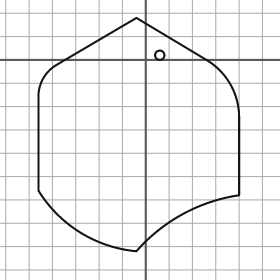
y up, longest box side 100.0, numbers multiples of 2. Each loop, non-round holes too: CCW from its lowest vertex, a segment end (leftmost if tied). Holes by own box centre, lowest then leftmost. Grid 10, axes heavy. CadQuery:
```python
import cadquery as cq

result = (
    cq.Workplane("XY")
    .moveTo(-4.0, -82.0)
    .threePointArc((16.0, -66.0), (40.0, -58.0))
    .lineTo(40.0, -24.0)
    .threePointArc((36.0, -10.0), (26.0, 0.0))
    .lineTo(-4.0, 18.0)
    .lineTo(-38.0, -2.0)
    .threePointArc((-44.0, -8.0), (-46.0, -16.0))
    .lineTo(-46.0, -56.0)
    .threePointArc((-28.0, -74.0), (-4.0, -82.0))
    .close()
    .moveTo(6.0, 2.0)
    .circle(2.0)
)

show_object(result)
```